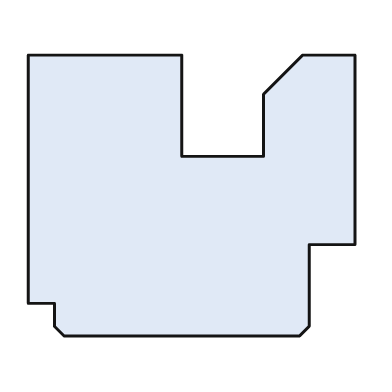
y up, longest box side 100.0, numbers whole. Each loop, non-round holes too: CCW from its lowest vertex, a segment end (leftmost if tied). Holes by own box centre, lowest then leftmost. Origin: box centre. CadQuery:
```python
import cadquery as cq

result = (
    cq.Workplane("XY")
    .moveTo(-39.0, -43.0)
    .lineTo(33.0, -43.0)
    .lineTo(36.0, -40.0)
    .lineTo(36.0, -15.0)
    .lineTo(50.0, -15.0)
    .lineTo(50.0, 43.0)
    .lineTo(34.0, 43.0)
    .lineTo(22.0, 31.0)
    .lineTo(22.0, 12.0)
    .lineTo(-3.0, 12.0)
    .lineTo(-3.0, 43.0)
    .lineTo(-50.0, 43.0)
    .lineTo(-50.0, -33.0)
    .lineTo(-42.0, -33.0)
    .lineTo(-42.0, -40.0)
    .close()
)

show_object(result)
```